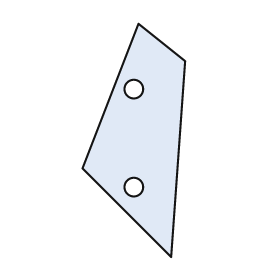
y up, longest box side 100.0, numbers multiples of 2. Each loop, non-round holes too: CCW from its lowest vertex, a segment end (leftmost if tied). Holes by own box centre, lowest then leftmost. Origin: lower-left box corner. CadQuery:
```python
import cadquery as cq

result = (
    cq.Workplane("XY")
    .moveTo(38.0, 0.0)
    .lineTo(44.0, 84.0)
    .lineTo(24.0, 100.0)
    .lineTo(0.0, 38.0)
    .close()
    .moveTo(22.0, 30.0)
    .circle(4.0)
    .moveTo(22.0, 72.0)
    .circle(4.0)
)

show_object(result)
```